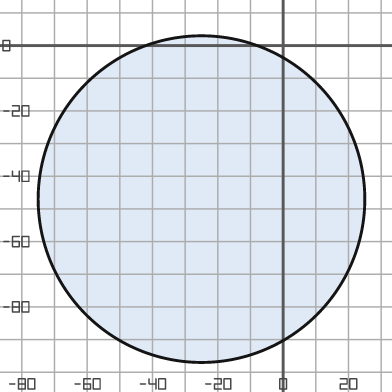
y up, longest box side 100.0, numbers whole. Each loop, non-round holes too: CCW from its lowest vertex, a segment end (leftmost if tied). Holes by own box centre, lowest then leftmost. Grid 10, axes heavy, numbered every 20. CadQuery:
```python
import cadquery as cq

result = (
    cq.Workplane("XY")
    .moveTo(-25.0, -47.0)
    .circle(50.0)
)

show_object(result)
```